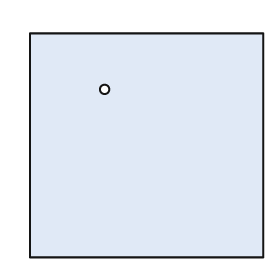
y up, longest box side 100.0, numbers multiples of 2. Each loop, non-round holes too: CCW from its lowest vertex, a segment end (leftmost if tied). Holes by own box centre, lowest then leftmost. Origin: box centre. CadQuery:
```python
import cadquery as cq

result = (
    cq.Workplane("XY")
    .moveTo(-50.0, -48.0)
    .lineTo(50.0, -48.0)
    .lineTo(50.0, 48.0)
    .lineTo(-50.0, 48.0)
    .close()
    .moveTo(-18.0, 24.0)
    .circle(2.0)
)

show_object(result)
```